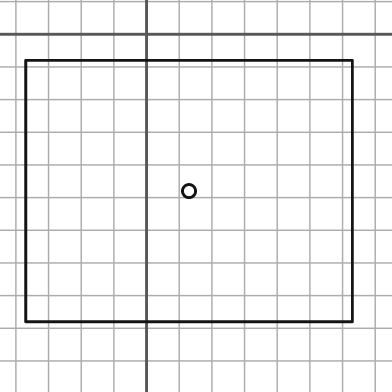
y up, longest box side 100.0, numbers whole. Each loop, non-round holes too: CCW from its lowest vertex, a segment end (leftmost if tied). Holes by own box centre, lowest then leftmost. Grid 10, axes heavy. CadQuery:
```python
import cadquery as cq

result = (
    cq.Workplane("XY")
    .moveTo(-37.0, -88.0)
    .lineTo(63.0, -88.0)
    .lineTo(63.0, -8.0)
    .lineTo(-37.0, -8.0)
    .close()
    .moveTo(13.0, -48.0)
    .circle(2.0)
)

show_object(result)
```